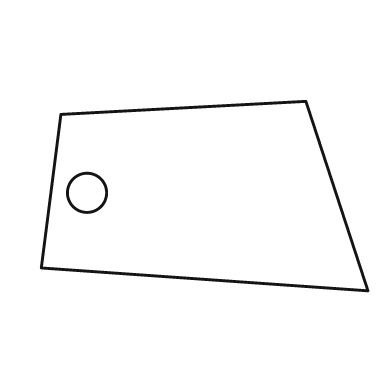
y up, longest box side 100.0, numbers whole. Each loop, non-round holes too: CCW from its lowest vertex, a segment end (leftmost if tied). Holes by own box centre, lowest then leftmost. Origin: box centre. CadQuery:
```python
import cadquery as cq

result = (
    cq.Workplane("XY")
    .moveTo(50.0, -29.0)
    .lineTo(31.0, 29.0)
    .lineTo(-44.0, 25.0)
    .lineTo(-50.0, -22.0)
    .close()
    .moveTo(-36.0, 1.0)
    .circle(6.0)
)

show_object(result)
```